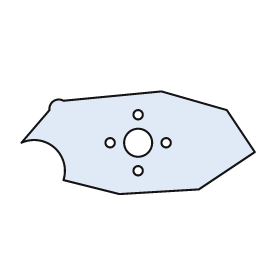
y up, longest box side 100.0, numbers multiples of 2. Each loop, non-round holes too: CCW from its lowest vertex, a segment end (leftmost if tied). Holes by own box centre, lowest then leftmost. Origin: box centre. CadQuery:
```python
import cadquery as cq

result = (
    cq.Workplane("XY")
    .moveTo(-8.0, -22.0)
    .lineTo(26.0, -20.0)
    .lineTo(50.0, -4.0)
    .lineTo(38.0, 14.0)
    .lineTo(10.0, 22.0)
    .lineTo(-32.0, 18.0)
    .threePointArc((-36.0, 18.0), (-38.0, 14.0))
    .lineTo(-50.0, 0.0)
    .threePointArc((-36.0, -2.0), (-32.0, -16.0))
    .close()
    .moveTo(0.0, -12.0)
    .circle(2.0)
    .moveTo(-12.0, 0.0)
    .circle(2.0)
    .moveTo(0.0, 0.0)
    .circle(6.0)
    .moveTo(12.0, 0.0)
    .circle(2.0)
    .moveTo(0.0, 12.0)
    .circle(2.0)
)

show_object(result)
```